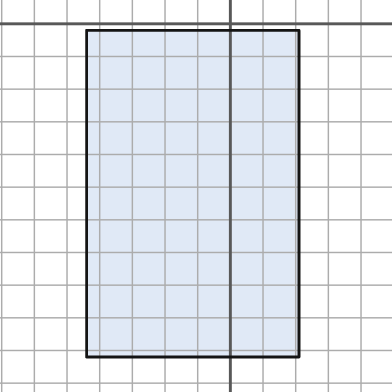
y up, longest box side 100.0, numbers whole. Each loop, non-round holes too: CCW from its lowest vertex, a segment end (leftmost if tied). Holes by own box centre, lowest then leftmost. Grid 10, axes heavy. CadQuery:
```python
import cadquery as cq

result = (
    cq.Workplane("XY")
    .moveTo(-44.0, -102.0)
    .lineTo(21.0, -102.0)
    .lineTo(21.0, -2.0)
    .lineTo(-44.0, -2.0)
    .close()
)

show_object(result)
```